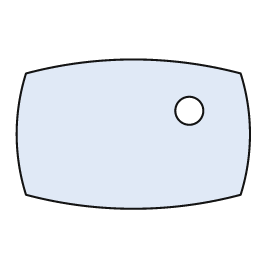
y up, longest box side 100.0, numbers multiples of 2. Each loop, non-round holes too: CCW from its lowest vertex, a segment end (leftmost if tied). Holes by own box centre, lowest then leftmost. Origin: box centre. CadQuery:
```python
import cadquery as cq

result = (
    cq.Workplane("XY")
    .moveTo(-46.0, -26.0)
    .threePointArc((0.0, -32.0), (46.0, -26.0))
    .threePointArc((50.0, 0.0), (46.0, 26.0))
    .threePointArc((0.0, 32.0), (-46.0, 26.0))
    .threePointArc((-50.0, 0.0), (-46.0, -26.0))
    .close()
    .moveTo(24.0, 10.0)
    .circle(6.0)
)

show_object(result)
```